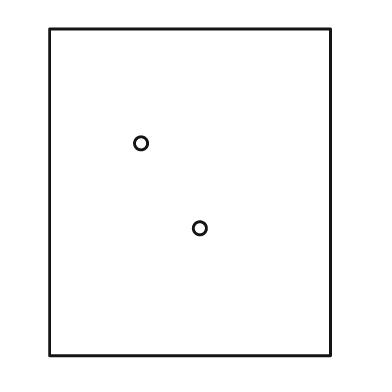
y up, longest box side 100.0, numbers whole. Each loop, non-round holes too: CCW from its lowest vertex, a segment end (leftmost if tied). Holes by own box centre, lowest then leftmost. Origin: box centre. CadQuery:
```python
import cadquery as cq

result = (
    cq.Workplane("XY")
    .moveTo(-43.0, -50.0)
    .lineTo(43.0, -50.0)
    .lineTo(43.0, 50.0)
    .lineTo(-43.0, 50.0)
    .close()
    .moveTo(3.0, -11.0)
    .circle(2.0)
    .moveTo(-15.0, 15.0)
    .circle(2.0)
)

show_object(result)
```